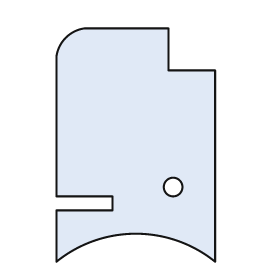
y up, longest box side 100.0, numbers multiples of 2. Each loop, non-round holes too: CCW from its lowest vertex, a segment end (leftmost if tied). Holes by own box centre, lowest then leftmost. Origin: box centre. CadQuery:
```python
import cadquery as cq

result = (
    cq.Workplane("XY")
    .moveTo(-34.0, -50.0)
    .threePointArc((0.0, -38.0), (34.0, -50.0))
    .lineTo(34.0, 32.0)
    .lineTo(14.0, 32.0)
    .lineTo(14.0, 50.0)
    .lineTo(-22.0, 50.0)
    .threePointArc((-30.0, 46.0), (-34.0, 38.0))
    .lineTo(-34.0, -22.0)
    .lineTo(-10.0, -22.0)
    .lineTo(-10.0, -28.0)
    .lineTo(-34.0, -28.0)
    .close()
    .moveTo(16.0, -18.0)
    .circle(4.0)
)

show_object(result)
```